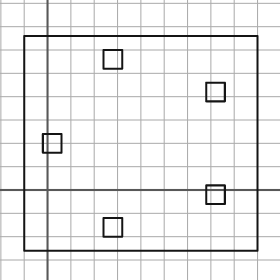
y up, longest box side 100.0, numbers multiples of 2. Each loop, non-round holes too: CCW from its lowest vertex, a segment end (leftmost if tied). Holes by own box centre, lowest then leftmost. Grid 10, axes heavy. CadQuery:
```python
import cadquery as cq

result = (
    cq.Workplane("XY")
    .moveTo(-10.0, -26.0)
    .lineTo(90.0, -26.0)
    .lineTo(90.0, 66.0)
    .lineTo(-10.0, 66.0)
    .close()
    .moveTo(24.0, -20.0)
    .lineTo(32.0, -20.0)
    .lineTo(32.0, -12.0)
    .lineTo(24.0, -12.0)
    .close()
    .moveTo(68.0, -6.0)
    .lineTo(76.0, -6.0)
    .lineTo(76.0, 2.0)
    .lineTo(68.0, 2.0)
    .close()
    .moveTo(-2.0, 16.0)
    .lineTo(6.0, 16.0)
    .lineTo(6.0, 24.0)
    .lineTo(-2.0, 24.0)
    .close()
    .moveTo(68.0, 38.0)
    .lineTo(76.0, 38.0)
    .lineTo(76.0, 46.0)
    .lineTo(68.0, 46.0)
    .close()
    .moveTo(24.0, 52.0)
    .lineTo(32.0, 52.0)
    .lineTo(32.0, 60.0)
    .lineTo(24.0, 60.0)
    .close()
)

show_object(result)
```